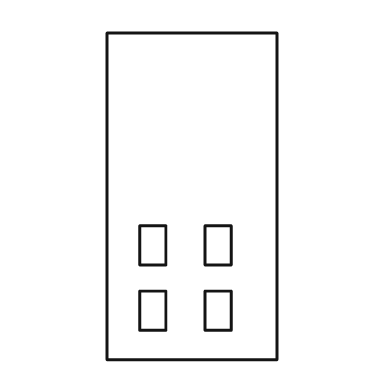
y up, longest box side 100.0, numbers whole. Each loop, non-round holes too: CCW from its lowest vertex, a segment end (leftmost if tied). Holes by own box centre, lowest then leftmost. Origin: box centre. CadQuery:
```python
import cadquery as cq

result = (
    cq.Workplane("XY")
    .moveTo(-26.0, -50.0)
    .lineTo(26.0, -50.0)
    .lineTo(26.0, 50.0)
    .lineTo(-26.0, 50.0)
    .close()
    .moveTo(-16.0, -41.0)
    .lineTo(-8.0, -41.0)
    .lineTo(-8.0, -29.0)
    .lineTo(-16.0, -29.0)
    .close()
    .moveTo(4.0, -41.0)
    .lineTo(12.0, -41.0)
    .lineTo(12.0, -29.0)
    .lineTo(4.0, -29.0)
    .close()
    .moveTo(-16.0, -21.0)
    .lineTo(-8.0, -21.0)
    .lineTo(-8.0, -9.0)
    .lineTo(-16.0, -9.0)
    .close()
    .moveTo(4.0, -21.0)
    .lineTo(12.0, -21.0)
    .lineTo(12.0, -9.0)
    .lineTo(4.0, -9.0)
    .close()
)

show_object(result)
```